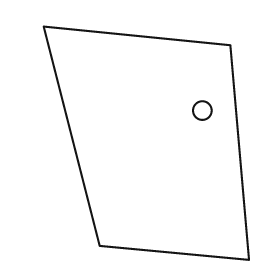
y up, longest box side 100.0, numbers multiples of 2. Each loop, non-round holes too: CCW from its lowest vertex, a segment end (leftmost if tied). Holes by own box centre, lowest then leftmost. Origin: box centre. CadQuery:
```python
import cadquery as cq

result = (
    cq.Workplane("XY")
    .moveTo(44.0, -50.0)
    .lineTo(36.0, 42.0)
    .lineTo(-44.0, 50.0)
    .lineTo(-20.0, -44.0)
    .close()
    .moveTo(24.0, 14.0)
    .circle(4.0)
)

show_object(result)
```